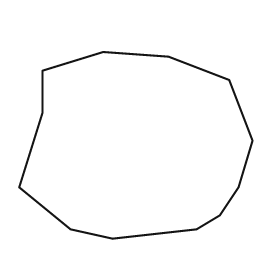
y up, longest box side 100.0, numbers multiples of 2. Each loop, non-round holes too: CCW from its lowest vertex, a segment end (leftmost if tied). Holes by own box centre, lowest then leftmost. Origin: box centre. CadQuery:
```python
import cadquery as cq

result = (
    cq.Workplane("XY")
    .moveTo(-10.0, -40.0)
    .lineTo(26.0, -36.0)
    .lineTo(36.0, -30.0)
    .lineTo(44.0, -18.0)
    .lineTo(50.0, 2.0)
    .lineTo(40.0, 28.0)
    .lineTo(14.0, 38.0)
    .lineTo(-14.0, 40.0)
    .lineTo(-40.0, 32.0)
    .lineTo(-40.0, 14.0)
    .lineTo(-50.0, -18.0)
    .lineTo(-28.0, -36.0)
    .close()
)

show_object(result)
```